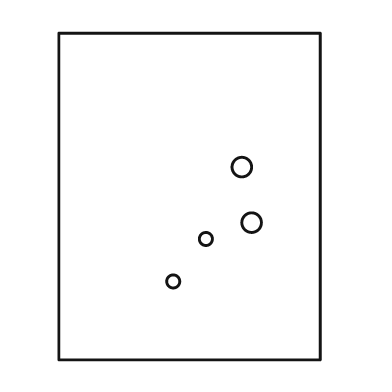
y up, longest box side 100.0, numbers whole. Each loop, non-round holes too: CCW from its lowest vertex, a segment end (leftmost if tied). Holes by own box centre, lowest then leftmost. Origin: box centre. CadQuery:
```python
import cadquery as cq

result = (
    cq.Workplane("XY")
    .moveTo(-40.0, -50.0)
    .lineTo(40.0, -50.0)
    .lineTo(40.0, 50.0)
    .lineTo(-40.0, 50.0)
    .close()
    .moveTo(-5.0, -26.0)
    .circle(2.0)
    .moveTo(5.0, -13.0)
    .circle(2.0)
    .moveTo(19.0, -8.0)
    .circle(3.0)
    .moveTo(16.0, 9.0)
    .circle(3.0)
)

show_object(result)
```